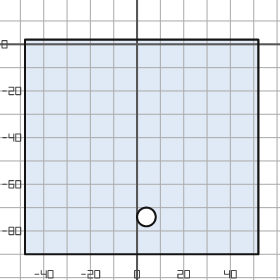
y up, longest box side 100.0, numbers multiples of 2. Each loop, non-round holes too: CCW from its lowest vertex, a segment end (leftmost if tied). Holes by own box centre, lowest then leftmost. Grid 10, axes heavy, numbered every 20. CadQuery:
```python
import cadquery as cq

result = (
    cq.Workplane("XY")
    .moveTo(-48.0, -90.0)
    .lineTo(52.0, -90.0)
    .lineTo(52.0, 2.0)
    .lineTo(-48.0, 2.0)
    .close()
    .moveTo(4.0, -74.0)
    .circle(4.0)
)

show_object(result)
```